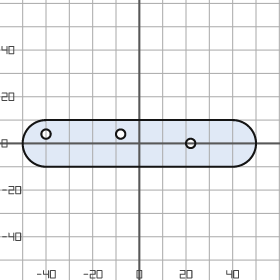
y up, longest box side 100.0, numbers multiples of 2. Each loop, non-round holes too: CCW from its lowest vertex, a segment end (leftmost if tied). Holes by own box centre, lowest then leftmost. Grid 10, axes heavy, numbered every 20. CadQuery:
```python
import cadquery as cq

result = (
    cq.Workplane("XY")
    .moveTo(-40.0, -10.0)
    .lineTo(40.0, -10.0)
    .threePointArc((50.0, 0.0), (40.0, 10.0))
    .lineTo(-40.0, 10.0)
    .threePointArc((-50.0, 0.0), (-40.0, -10.0))
    .close()
    .moveTo(22.0, 0.0)
    .circle(2.0)
    .moveTo(-40.0, 4.0)
    .circle(2.0)
    .moveTo(-8.0, 4.0)
    .circle(2.0)
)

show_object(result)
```